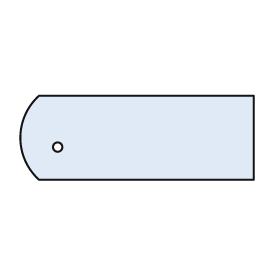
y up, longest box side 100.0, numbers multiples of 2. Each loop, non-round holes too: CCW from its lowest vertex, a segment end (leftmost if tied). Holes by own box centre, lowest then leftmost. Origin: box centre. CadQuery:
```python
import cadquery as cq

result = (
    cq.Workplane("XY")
    .moveTo(-42.0, -18.0)
    .lineTo(50.0, -18.0)
    .lineTo(50.0, 18.0)
    .lineTo(-42.0, 18.0)
    .threePointArc((-50.0, 0.0), (-42.0, -18.0))
    .close()
    .moveTo(-34.0, -4.0)
    .circle(2.0)
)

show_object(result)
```